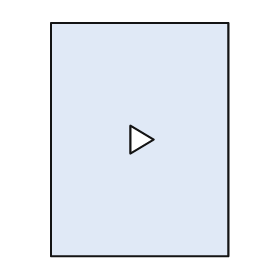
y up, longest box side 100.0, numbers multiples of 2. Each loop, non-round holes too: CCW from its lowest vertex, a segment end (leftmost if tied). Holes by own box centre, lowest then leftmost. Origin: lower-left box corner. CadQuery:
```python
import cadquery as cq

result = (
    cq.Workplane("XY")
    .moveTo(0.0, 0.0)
    .lineTo(76.0, 0.0)
    .lineTo(76.0, 100.0)
    .lineTo(0.0, 100.0)
    .close()
    .moveTo(34.0, 44.0)
    .lineTo(44.0, 50.0)
    .lineTo(34.0, 56.0)
    .close()
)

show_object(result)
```